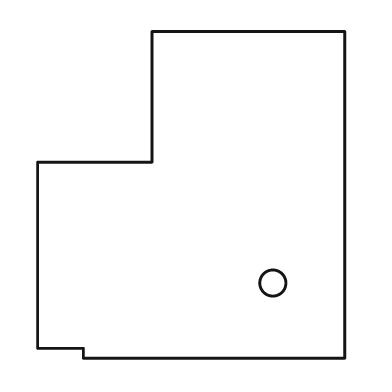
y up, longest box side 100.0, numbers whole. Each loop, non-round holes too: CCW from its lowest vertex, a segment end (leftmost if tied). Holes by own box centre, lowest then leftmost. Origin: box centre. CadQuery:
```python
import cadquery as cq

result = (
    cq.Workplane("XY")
    .moveTo(-33.0, -50.0)
    .lineTo(47.0, -50.0)
    .lineTo(47.0, 50.0)
    .lineTo(-12.0, 50.0)
    .lineTo(-12.0, 10.0)
    .lineTo(-47.0, 10.0)
    .lineTo(-47.0, -47.0)
    .lineTo(-33.0, -47.0)
    .close()
    .moveTo(25.0, -27.0)
    .circle(4.0)
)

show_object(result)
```